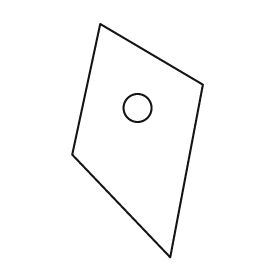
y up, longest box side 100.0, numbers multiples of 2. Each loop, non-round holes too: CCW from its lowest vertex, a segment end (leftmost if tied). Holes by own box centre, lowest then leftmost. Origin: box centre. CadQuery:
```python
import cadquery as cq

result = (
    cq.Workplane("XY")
    .moveTo(14.0, -50.0)
    .lineTo(28.0, 24.0)
    .lineTo(-16.0, 50.0)
    .lineTo(-28.0, -6.0)
    .close()
    .moveTo(0.0, 14.0)
    .circle(6.0)
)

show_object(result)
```